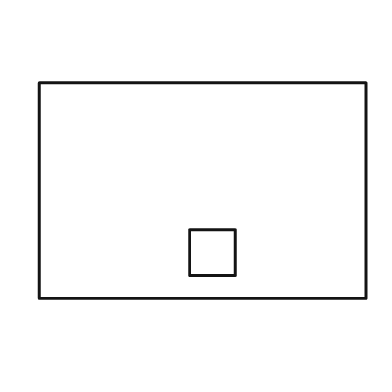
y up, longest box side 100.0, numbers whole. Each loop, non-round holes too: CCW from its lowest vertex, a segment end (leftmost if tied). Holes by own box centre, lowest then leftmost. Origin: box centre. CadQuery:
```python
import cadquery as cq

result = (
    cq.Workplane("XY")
    .moveTo(-50.0, -33.0)
    .lineTo(50.0, -33.0)
    .lineTo(50.0, 33.0)
    .lineTo(-50.0, 33.0)
    .close()
    .moveTo(-4.0, -26.0)
    .lineTo(10.0, -26.0)
    .lineTo(10.0, -12.0)
    .lineTo(-4.0, -12.0)
    .close()
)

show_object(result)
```